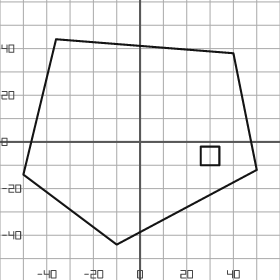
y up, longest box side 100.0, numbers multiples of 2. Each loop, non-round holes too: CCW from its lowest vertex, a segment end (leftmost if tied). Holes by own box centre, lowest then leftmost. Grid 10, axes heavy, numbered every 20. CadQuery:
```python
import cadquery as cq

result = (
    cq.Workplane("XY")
    .moveTo(-10.0, -44.0)
    .lineTo(50.0, -12.0)
    .lineTo(40.0, 38.0)
    .lineTo(-36.0, 44.0)
    .lineTo(-50.0, -14.0)
    .close()
    .moveTo(26.0, -10.0)
    .lineTo(34.0, -10.0)
    .lineTo(34.0, -2.0)
    .lineTo(26.0, -2.0)
    .close()
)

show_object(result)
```